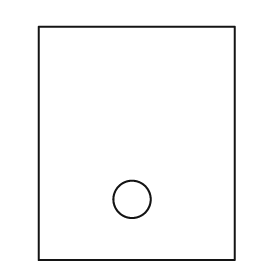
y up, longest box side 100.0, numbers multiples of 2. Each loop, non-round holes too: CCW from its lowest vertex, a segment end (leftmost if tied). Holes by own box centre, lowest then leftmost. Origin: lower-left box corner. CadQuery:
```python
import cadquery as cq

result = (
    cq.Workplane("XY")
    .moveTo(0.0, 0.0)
    .lineTo(84.0, 0.0)
    .lineTo(84.0, 100.0)
    .lineTo(0.0, 100.0)
    .close()
    .moveTo(40.0, 26.0)
    .circle(8.0)
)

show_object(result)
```